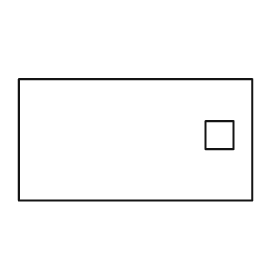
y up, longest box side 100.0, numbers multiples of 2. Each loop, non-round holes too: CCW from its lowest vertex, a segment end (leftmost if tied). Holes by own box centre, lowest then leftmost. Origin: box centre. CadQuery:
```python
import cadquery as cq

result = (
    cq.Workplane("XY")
    .moveTo(-50.0, -26.0)
    .lineTo(50.0, -26.0)
    .lineTo(50.0, 26.0)
    .lineTo(-50.0, 26.0)
    .close()
    .moveTo(30.0, -4.0)
    .lineTo(42.0, -4.0)
    .lineTo(42.0, 8.0)
    .lineTo(30.0, 8.0)
    .close()
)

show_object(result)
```